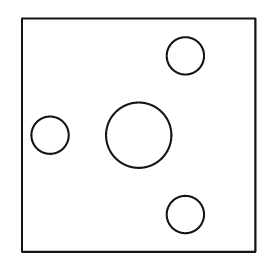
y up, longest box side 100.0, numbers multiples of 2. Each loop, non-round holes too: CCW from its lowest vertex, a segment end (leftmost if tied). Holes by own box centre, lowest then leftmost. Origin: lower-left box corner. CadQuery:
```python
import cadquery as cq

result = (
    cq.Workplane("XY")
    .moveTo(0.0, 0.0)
    .lineTo(100.0, 0.0)
    .lineTo(100.0, 100.0)
    .lineTo(0.0, 100.0)
    .close()
    .moveTo(70.0, 16.0)
    .circle(8.0)
    .moveTo(12.0, 50.0)
    .circle(8.0)
    .moveTo(50.0, 50.0)
    .circle(14.0)
    .moveTo(70.0, 84.0)
    .circle(8.0)
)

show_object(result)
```